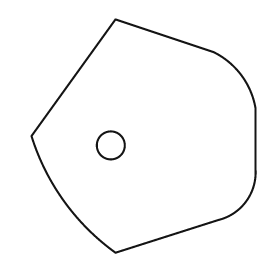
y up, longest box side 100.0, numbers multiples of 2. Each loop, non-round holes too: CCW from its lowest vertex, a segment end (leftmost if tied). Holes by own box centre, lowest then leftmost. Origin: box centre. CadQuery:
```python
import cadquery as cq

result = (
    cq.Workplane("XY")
    .moveTo(-12.0, -50.0)
    .lineTo(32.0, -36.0)
    .threePointArc((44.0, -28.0), (48.0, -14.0))
    .lineTo(48.0, 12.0)
    .threePointArc((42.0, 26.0), (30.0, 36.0))
    .lineTo(-12.0, 50.0)
    .lineTo(-48.0, 0.0)
    .threePointArc((-34.0, -28.0), (-12.0, -50.0))
    .close()
    .moveTo(-14.0, -4.0)
    .circle(6.0)
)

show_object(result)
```